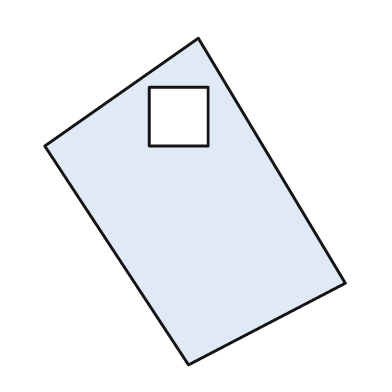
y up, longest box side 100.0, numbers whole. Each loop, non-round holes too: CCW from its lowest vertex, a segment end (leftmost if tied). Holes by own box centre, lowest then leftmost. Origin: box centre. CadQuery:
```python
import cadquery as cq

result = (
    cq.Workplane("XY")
    .moveTo(-2.0, -50.0)
    .lineTo(46.0, -25.0)
    .lineTo(1.0, 50.0)
    .lineTo(-46.0, 17.0)
    .close()
    .moveTo(-14.0, 17.0)
    .lineTo(4.0, 17.0)
    .lineTo(4.0, 35.0)
    .lineTo(-14.0, 35.0)
    .close()
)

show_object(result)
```